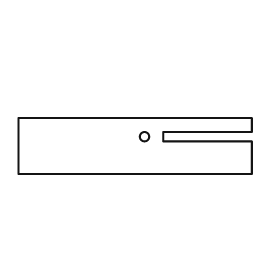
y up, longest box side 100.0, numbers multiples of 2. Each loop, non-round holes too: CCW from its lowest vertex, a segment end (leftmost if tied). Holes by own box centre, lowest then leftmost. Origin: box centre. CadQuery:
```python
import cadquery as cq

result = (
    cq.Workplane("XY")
    .moveTo(-50.0, -12.0)
    .lineTo(50.0, -12.0)
    .lineTo(50.0, 2.0)
    .lineTo(12.0, 2.0)
    .lineTo(12.0, 6.0)
    .lineTo(50.0, 6.0)
    .lineTo(50.0, 12.0)
    .lineTo(-50.0, 12.0)
    .close()
    .moveTo(4.0, 4.0)
    .circle(2.0)
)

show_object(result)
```